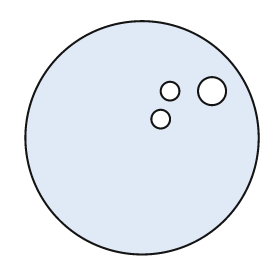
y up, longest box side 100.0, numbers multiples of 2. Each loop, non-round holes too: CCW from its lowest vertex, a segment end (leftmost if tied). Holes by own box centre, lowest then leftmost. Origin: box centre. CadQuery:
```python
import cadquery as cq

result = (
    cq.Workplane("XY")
    .moveTo(0.0, 0.0)
    .circle(50.0)
    .moveTo(8.0, 8.0)
    .circle(4.0)
    .moveTo(12.0, 20.0)
    .circle(4.0)
    .moveTo(30.0, 20.0)
    .circle(6.0)
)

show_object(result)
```